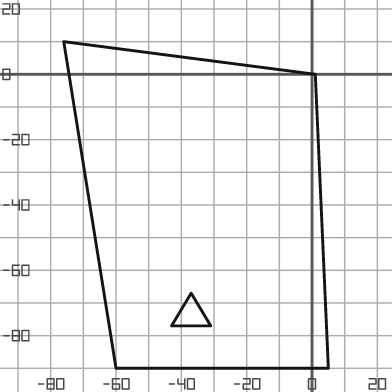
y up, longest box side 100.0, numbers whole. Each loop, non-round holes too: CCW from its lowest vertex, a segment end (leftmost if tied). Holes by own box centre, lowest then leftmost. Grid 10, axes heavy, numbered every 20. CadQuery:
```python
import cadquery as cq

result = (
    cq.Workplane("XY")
    .moveTo(-60.0, -90.0)
    .lineTo(5.0, -90.0)
    .lineTo(1.0, 0.0)
    .lineTo(-76.0, 10.0)
    .close()
    .moveTo(-43.0, -77.0)
    .lineTo(-31.0, -77.0)
    .lineTo(-37.0, -67.0)
    .close()
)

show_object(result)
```